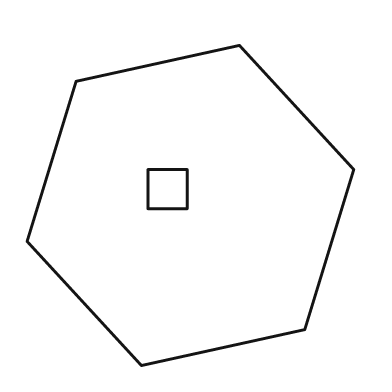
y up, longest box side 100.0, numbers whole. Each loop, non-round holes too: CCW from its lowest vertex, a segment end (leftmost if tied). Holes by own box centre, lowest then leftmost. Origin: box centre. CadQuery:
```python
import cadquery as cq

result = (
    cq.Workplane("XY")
    .moveTo(-15.0, -49.0)
    .lineTo(35.0, -38.0)
    .lineTo(50.0, 11.0)
    .lineTo(15.0, 49.0)
    .lineTo(-35.0, 38.0)
    .lineTo(-50.0, -11.0)
    .close()
    .moveTo(-13.0, -1.0)
    .lineTo(-1.0, -1.0)
    .lineTo(-1.0, 11.0)
    .lineTo(-13.0, 11.0)
    .close()
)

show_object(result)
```